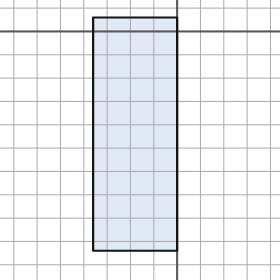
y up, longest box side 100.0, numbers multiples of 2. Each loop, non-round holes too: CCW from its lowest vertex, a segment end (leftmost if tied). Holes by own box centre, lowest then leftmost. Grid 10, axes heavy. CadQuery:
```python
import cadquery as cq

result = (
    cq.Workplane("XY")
    .moveTo(-36.0, -94.0)
    .lineTo(0.0, -94.0)
    .lineTo(0.0, 6.0)
    .lineTo(-36.0, 6.0)
    .close()
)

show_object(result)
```